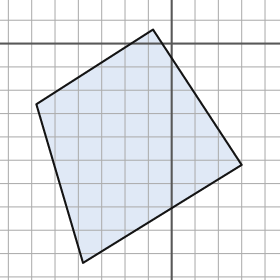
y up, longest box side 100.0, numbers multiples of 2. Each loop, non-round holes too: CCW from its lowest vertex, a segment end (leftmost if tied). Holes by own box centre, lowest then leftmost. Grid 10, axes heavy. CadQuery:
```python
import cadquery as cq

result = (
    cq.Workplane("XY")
    .moveTo(-38.0, -94.0)
    .lineTo(30.0, -52.0)
    .lineTo(-8.0, 6.0)
    .lineTo(-58.0, -26.0)
    .close()
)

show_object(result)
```